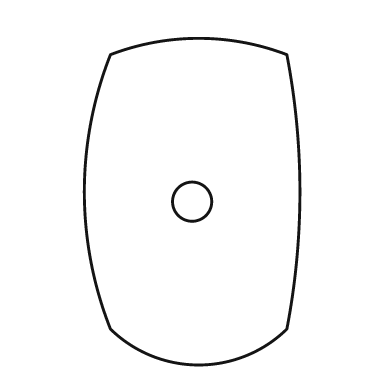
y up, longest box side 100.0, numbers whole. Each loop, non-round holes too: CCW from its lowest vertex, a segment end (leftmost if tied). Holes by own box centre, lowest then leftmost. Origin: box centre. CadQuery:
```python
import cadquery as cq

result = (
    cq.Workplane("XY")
    .moveTo(-25.0, -39.0)
    .threePointArc((2.0, -50.0), (29.0, -39.0))
    .threePointArc((33.0, 3.0), (29.0, 45.0))
    .threePointArc((2.0, 50.0), (-25.0, 45.0))
    .threePointArc((-33.0, 3.0), (-25.0, -39.0))
    .close()
    .moveTo(0.0, 0.0)
    .circle(6.0)
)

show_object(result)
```